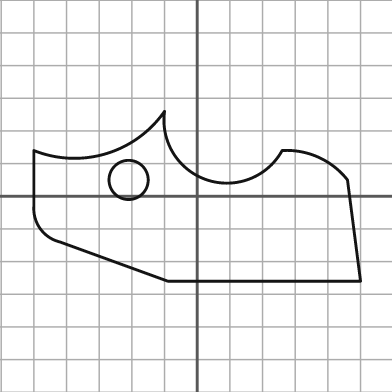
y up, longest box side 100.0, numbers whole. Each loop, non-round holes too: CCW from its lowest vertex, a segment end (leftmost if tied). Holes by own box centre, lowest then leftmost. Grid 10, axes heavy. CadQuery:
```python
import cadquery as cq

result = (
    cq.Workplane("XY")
    .moveTo(-9.0, -26.0)
    .lineTo(50.0, -26.0)
    .lineTo(46.0, 5.0)
    .threePointArc((37.0, 12.0), (26.0, 14.0))
    .threePointArc((3.0, 5.0), (-10.0, 26.0))
    .threePointArc((-28.0, 13.0), (-50.0, 14.0))
    .lineTo(-50.0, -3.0)
    .threePointArc((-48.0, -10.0), (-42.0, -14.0))
    .close()
    .moveTo(-21.0, 5.0)
    .circle(6.0)
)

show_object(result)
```